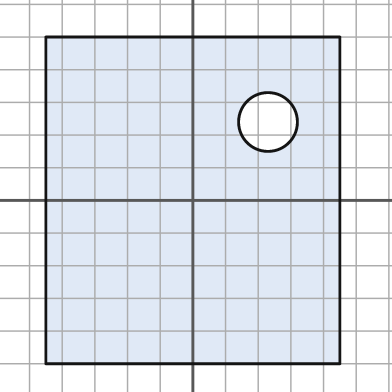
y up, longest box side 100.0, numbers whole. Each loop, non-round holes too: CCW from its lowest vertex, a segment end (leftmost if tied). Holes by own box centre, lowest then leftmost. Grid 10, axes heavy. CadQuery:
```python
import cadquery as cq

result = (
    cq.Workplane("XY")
    .moveTo(-45.0, -50.0)
    .lineTo(45.0, -50.0)
    .lineTo(45.0, 50.0)
    .lineTo(-45.0, 50.0)
    .close()
    .moveTo(23.0, 24.0)
    .circle(9.0)
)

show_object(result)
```